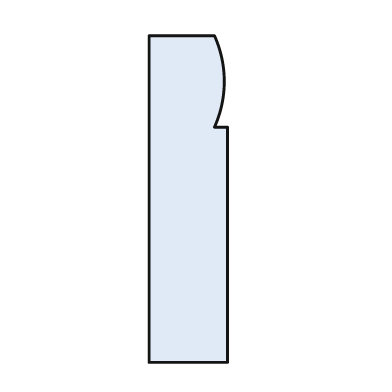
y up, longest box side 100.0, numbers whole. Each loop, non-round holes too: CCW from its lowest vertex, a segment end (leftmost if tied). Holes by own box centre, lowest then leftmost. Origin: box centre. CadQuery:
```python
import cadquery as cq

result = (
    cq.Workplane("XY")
    .moveTo(-12.0, -50.0)
    .lineTo(12.0, -50.0)
    .lineTo(12.0, 22.0)
    .lineTo(8.0, 22.0)
    .threePointArc((11.0, 36.0), (8.0, 50.0))
    .lineTo(-12.0, 50.0)
    .close()
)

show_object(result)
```